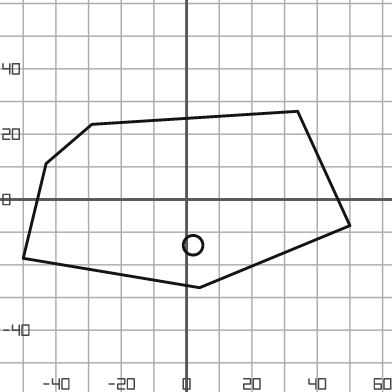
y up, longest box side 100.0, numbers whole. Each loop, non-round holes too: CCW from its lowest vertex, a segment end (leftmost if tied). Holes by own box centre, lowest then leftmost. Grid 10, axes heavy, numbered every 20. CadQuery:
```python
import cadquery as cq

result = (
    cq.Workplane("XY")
    .moveTo(4.0, -27.0)
    .lineTo(50.0, -8.0)
    .lineTo(34.0, 27.0)
    .lineTo(-29.0, 23.0)
    .lineTo(-43.0, 11.0)
    .lineTo(-50.0, -18.0)
    .close()
    .moveTo(2.0, -14.0)
    .circle(3.0)
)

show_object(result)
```